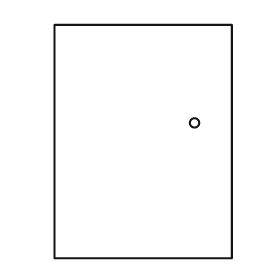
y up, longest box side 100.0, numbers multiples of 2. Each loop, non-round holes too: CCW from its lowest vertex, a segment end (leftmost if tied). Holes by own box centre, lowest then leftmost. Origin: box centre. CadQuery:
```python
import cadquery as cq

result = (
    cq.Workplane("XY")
    .moveTo(-38.0, -50.0)
    .lineTo(38.0, -50.0)
    .lineTo(38.0, 50.0)
    .lineTo(-38.0, 50.0)
    .close()
    .moveTo(22.0, 8.0)
    .circle(2.0)
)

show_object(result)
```